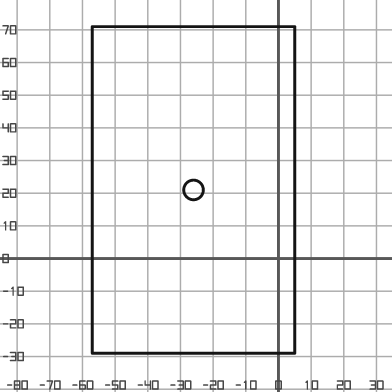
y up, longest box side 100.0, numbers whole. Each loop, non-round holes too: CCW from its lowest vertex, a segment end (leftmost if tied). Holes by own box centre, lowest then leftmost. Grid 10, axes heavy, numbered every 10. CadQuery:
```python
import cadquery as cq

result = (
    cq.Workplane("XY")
    .moveTo(-57.0, -29.0)
    .lineTo(5.0, -29.0)
    .lineTo(5.0, 71.0)
    .lineTo(-57.0, 71.0)
    .close()
    .moveTo(-26.0, 21.0)
    .circle(3.0)
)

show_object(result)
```